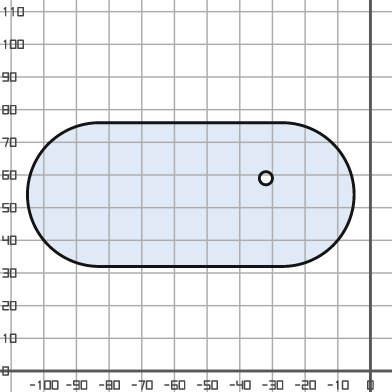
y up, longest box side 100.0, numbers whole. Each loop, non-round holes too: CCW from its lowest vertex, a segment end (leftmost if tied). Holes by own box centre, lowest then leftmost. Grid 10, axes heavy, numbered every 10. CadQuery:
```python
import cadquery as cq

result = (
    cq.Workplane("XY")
    .moveTo(-83.0, 32.0)
    .lineTo(-27.0, 32.0)
    .threePointArc((-5.0, 54.0), (-27.0, 76.0))
    .lineTo(-83.0, 76.0)
    .threePointArc((-105.0, 54.0), (-83.0, 32.0))
    .close()
    .moveTo(-32.0, 59.0)
    .circle(2.0)
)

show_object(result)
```